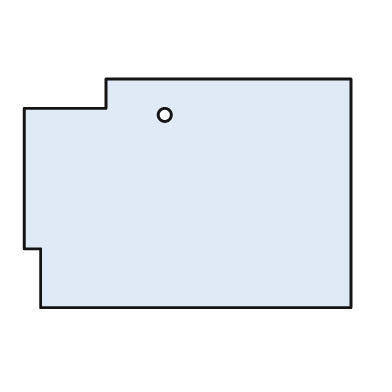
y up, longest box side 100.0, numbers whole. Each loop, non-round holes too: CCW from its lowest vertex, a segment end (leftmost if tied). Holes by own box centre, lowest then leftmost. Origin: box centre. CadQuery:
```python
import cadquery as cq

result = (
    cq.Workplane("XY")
    .moveTo(-45.0, -35.0)
    .lineTo(50.0, -35.0)
    .lineTo(50.0, 35.0)
    .lineTo(-25.0, 35.0)
    .lineTo(-25.0, 26.0)
    .lineTo(-50.0, 26.0)
    .lineTo(-50.0, -17.0)
    .lineTo(-45.0, -17.0)
    .close()
    .moveTo(-7.0, 24.0)
    .circle(2.0)
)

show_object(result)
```